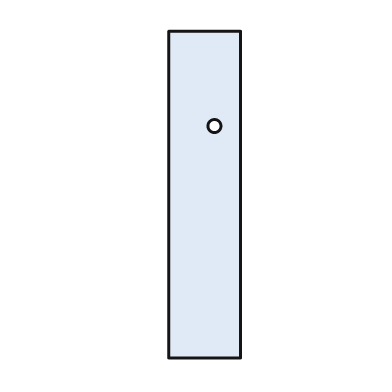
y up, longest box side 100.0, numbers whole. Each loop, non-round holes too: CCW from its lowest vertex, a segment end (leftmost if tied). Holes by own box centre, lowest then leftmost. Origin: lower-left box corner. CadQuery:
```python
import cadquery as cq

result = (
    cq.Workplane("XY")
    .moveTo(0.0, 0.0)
    .lineTo(22.0, 0.0)
    .lineTo(22.0, 100.0)
    .lineTo(0.0, 100.0)
    .close()
    .moveTo(14.0, 71.0)
    .circle(2.0)
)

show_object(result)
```